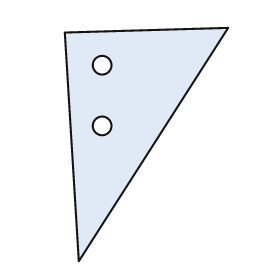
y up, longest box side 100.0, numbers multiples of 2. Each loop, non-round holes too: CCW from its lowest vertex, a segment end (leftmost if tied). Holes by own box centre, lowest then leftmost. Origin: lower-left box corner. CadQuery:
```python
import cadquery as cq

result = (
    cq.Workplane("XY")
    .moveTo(6.0, 0.0)
    .lineTo(70.0, 100.0)
    .lineTo(0.0, 98.0)
    .close()
    .moveTo(16.0, 58.0)
    .circle(4.0)
    .moveTo(16.0, 84.0)
    .circle(4.0)
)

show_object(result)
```